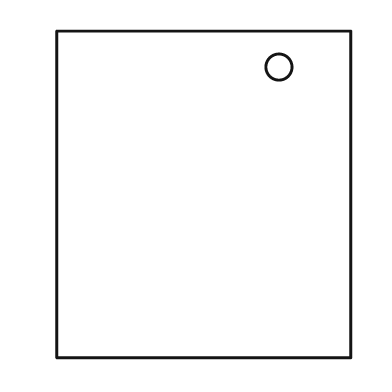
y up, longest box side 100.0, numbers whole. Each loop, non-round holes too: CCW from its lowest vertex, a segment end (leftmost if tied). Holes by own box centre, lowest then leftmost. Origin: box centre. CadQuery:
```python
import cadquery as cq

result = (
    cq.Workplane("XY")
    .moveTo(-45.0, -50.0)
    .lineTo(45.0, -50.0)
    .lineTo(45.0, 50.0)
    .lineTo(-45.0, 50.0)
    .close()
    .moveTo(23.0, 39.0)
    .circle(4.0)
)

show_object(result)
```